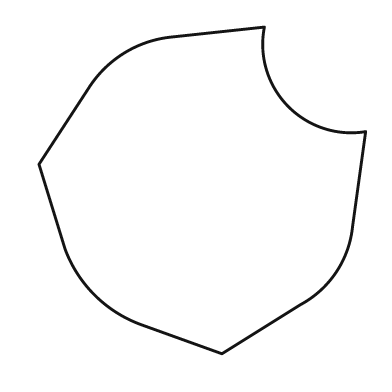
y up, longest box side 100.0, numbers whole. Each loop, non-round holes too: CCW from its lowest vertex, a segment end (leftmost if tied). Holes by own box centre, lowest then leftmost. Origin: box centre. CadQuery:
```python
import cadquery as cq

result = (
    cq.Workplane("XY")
    .moveTo(6.0, -50.0)
    .lineTo(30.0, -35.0)
    .threePointArc((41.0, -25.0), (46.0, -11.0))
    .lineTo(50.0, 18.0)
    .threePointArc((26.0, 26.0), (19.0, 50.0))
    .lineTo(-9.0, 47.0)
    .threePointArc((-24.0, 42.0), (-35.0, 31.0))
    .lineTo(-50.0, 8.0)
    .lineTo(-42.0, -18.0)
    .threePointArc((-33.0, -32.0), (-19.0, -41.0))
    .close()
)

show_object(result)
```